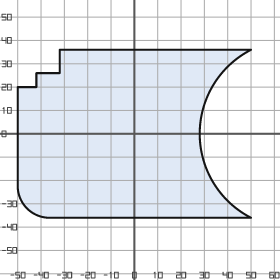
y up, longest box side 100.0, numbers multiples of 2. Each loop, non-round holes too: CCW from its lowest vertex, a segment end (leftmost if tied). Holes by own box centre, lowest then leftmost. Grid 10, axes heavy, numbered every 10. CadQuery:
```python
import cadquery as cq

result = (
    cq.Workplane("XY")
    .moveTo(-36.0, -36.0)
    .lineTo(50.0, -36.0)
    .threePointArc((28.0, 0.0), (50.0, 36.0))
    .lineTo(-32.0, 36.0)
    .lineTo(-32.0, 26.0)
    .lineTo(-42.0, 26.0)
    .lineTo(-42.0, 20.0)
    .lineTo(-50.0, 20.0)
    .lineTo(-50.0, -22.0)
    .threePointArc((-46.0, -32.0), (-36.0, -36.0))
    .close()
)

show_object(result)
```